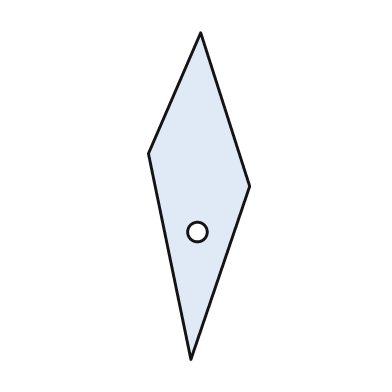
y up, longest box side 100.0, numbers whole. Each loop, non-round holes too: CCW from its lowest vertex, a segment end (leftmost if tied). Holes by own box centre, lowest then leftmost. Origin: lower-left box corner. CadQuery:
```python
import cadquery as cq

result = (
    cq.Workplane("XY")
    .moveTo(13.0, 0.0)
    .lineTo(31.0, 53.0)
    .lineTo(16.0, 100.0)
    .lineTo(0.0, 63.0)
    .close()
    .moveTo(15.0, 39.0)
    .circle(3.0)
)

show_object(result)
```